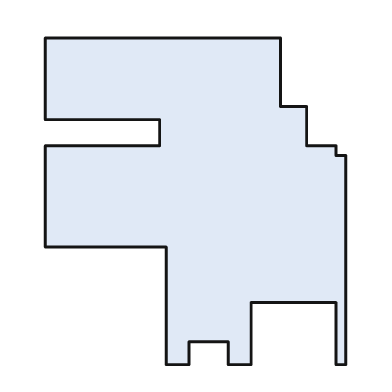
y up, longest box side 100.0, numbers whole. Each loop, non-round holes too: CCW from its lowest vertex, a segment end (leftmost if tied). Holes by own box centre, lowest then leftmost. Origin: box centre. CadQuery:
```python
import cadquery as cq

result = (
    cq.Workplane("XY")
    .moveTo(-9.0, -50.0)
    .lineTo(-2.0, -50.0)
    .lineTo(-2.0, -43.0)
    .lineTo(10.0, -43.0)
    .lineTo(10.0, -50.0)
    .lineTo(17.0, -50.0)
    .lineTo(17.0, -31.0)
    .lineTo(43.0, -31.0)
    .lineTo(43.0, -50.0)
    .lineTo(46.0, -50.0)
    .lineTo(46.0, 14.0)
    .lineTo(43.0, 14.0)
    .lineTo(43.0, 17.0)
    .lineTo(34.0, 17.0)
    .lineTo(34.0, 29.0)
    .lineTo(26.0, 29.0)
    .lineTo(26.0, 50.0)
    .lineTo(-46.0, 50.0)
    .lineTo(-46.0, 25.0)
    .lineTo(-11.0, 25.0)
    .lineTo(-11.0, 17.0)
    .lineTo(-46.0, 17.0)
    .lineTo(-46.0, -14.0)
    .lineTo(-9.0, -14.0)
    .close()
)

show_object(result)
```